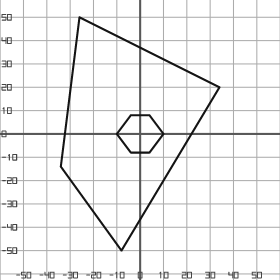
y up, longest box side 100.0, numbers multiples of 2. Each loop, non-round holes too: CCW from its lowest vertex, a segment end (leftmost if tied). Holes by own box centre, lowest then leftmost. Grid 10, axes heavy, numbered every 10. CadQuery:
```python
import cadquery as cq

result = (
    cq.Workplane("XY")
    .moveTo(-8.0, -50.0)
    .lineTo(34.0, 20.0)
    .lineTo(-26.0, 50.0)
    .lineTo(-34.0, -14.0)
    .close()
    .moveTo(-4.0, -8.0)
    .lineTo(4.0, -8.0)
    .lineTo(10.0, 0.0)
    .lineTo(4.0, 8.0)
    .lineTo(-4.0, 8.0)
    .lineTo(-10.0, 0.0)
    .close()
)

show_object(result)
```